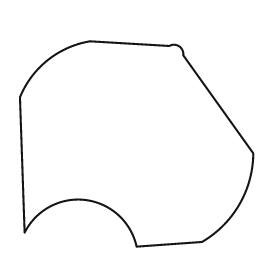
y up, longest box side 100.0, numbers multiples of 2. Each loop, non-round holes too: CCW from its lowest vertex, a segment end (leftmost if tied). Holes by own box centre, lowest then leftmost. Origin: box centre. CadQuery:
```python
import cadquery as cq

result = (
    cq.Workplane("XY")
    .moveTo(0.0, -44.0)
    .lineTo(28.0, -42.0)
    .threePointArc((44.0, -26.0), (50.0, -4.0))
    .lineTo(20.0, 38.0)
    .threePointArc((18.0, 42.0), (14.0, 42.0))
    .lineTo(-20.0, 44.0)
    .threePointArc((-38.0, 36.0), (-50.0, 20.0))
    .lineTo(-48.0, -38.0)
    .threePointArc((-22.0, -24.0), (0.0, -44.0))
    .close()
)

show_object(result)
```